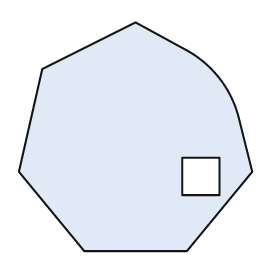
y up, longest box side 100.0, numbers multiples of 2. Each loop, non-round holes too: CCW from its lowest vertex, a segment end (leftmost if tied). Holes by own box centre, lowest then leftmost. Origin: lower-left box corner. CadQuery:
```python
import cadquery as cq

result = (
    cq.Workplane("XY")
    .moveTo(28.0, 0.0)
    .lineTo(72.0, 0.0)
    .lineTo(100.0, 34.0)
    .lineTo(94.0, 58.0)
    .threePointArc((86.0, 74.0), (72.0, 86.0))
    .lineTo(50.0, 98.0)
    .lineTo(10.0, 78.0)
    .lineTo(0.0, 34.0)
    .close()
    .moveTo(70.0, 24.0)
    .lineTo(86.0, 24.0)
    .lineTo(86.0, 40.0)
    .lineTo(70.0, 40.0)
    .close()
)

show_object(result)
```